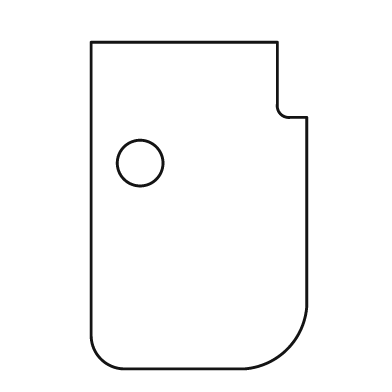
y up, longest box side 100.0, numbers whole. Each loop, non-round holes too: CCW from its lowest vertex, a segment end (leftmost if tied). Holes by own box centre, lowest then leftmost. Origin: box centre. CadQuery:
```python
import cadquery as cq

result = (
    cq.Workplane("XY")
    .moveTo(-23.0, -50.0)
    .lineTo(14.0, -50.0)
    .threePointArc((27.0, -44.0), (33.0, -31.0))
    .lineTo(33.0, 27.0)
    .lineTo(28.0, 27.0)
    .threePointArc((25.0, 28.0), (24.0, 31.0))
    .lineTo(24.0, 50.0)
    .lineTo(-33.0, 50.0)
    .lineTo(-33.0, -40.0)
    .threePointArc((-30.0, -47.0), (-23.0, -50.0))
    .close()
    .moveTo(-18.0, 13.0)
    .circle(7.0)
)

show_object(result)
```